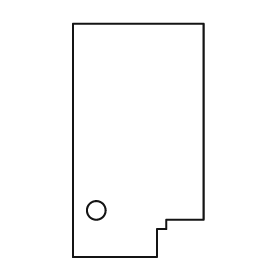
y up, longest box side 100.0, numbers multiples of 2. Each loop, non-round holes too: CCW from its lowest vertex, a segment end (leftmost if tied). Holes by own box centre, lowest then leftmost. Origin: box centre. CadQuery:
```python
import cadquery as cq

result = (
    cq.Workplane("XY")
    .moveTo(-28.0, -50.0)
    .lineTo(8.0, -50.0)
    .lineTo(8.0, -38.0)
    .lineTo(12.0, -38.0)
    .lineTo(12.0, -34.0)
    .lineTo(28.0, -34.0)
    .lineTo(28.0, 50.0)
    .lineTo(-28.0, 50.0)
    .close()
    .moveTo(-18.0, -30.0)
    .circle(4.0)
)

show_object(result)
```